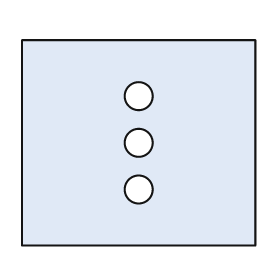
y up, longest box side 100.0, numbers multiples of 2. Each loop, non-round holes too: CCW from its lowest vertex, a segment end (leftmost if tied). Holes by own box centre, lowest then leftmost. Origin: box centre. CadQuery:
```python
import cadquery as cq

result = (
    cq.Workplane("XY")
    .moveTo(-50.0, -44.0)
    .lineTo(50.0, -44.0)
    .lineTo(50.0, 44.0)
    .lineTo(-50.0, 44.0)
    .close()
    .moveTo(0.0, -20.0)
    .circle(6.0)
    .moveTo(0.0, 0.0)
    .circle(6.0)
    .moveTo(0.0, 20.0)
    .circle(6.0)
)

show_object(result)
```